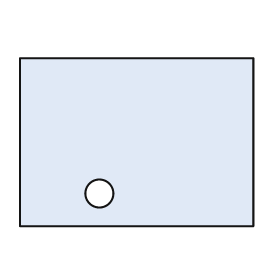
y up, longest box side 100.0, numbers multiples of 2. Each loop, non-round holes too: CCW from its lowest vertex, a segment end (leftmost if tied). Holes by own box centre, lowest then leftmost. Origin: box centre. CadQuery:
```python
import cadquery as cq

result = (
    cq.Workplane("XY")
    .moveTo(-50.0, -36.0)
    .lineTo(50.0, -36.0)
    .lineTo(50.0, 36.0)
    .lineTo(-50.0, 36.0)
    .close()
    .moveTo(-16.0, -22.0)
    .circle(6.0)
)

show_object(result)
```